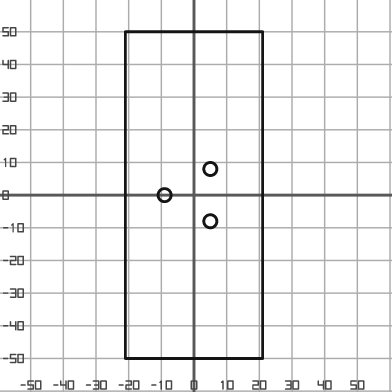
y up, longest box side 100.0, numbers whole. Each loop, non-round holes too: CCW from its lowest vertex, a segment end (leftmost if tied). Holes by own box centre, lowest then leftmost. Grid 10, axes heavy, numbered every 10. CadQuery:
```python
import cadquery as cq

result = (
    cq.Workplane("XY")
    .moveTo(-21.0, -50.0)
    .lineTo(21.0, -50.0)
    .lineTo(21.0, 50.0)
    .lineTo(-21.0, 50.0)
    .close()
    .moveTo(5.0, -8.0)
    .circle(2.0)
    .moveTo(-9.0, 0.0)
    .circle(2.0)
    .moveTo(5.0, 8.0)
    .circle(2.0)
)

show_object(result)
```